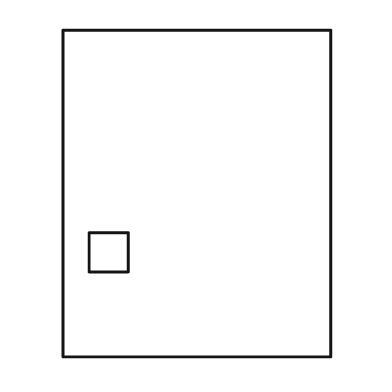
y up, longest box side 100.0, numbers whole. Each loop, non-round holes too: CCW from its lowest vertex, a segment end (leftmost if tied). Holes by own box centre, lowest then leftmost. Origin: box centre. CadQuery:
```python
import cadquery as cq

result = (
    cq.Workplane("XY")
    .moveTo(-41.0, -50.0)
    .lineTo(41.0, -50.0)
    .lineTo(41.0, 50.0)
    .lineTo(-41.0, 50.0)
    .close()
    .moveTo(-33.0, -24.0)
    .lineTo(-21.0, -24.0)
    .lineTo(-21.0, -12.0)
    .lineTo(-33.0, -12.0)
    .close()
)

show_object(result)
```